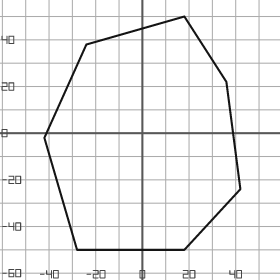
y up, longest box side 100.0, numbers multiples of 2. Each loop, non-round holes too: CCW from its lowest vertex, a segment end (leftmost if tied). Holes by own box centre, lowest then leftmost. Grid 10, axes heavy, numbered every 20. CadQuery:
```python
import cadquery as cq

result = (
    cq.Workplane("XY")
    .moveTo(-28.0, -50.0)
    .lineTo(18.0, -50.0)
    .lineTo(42.0, -24.0)
    .lineTo(36.0, 22.0)
    .lineTo(18.0, 50.0)
    .lineTo(-24.0, 38.0)
    .lineTo(-42.0, -2.0)
    .close()
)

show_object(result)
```